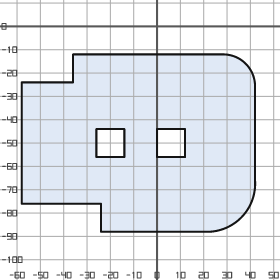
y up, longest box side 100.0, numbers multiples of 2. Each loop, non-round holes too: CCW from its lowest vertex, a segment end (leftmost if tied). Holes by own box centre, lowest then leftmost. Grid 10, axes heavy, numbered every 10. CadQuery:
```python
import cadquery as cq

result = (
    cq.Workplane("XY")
    .moveTo(-24.0, -88.0)
    .lineTo(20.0, -88.0)
    .threePointArc((36.0, -82.0), (42.0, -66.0))
    .lineTo(42.0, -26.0)
    .threePointArc((38.0, -16.0), (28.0, -12.0))
    .lineTo(-36.0, -12.0)
    .lineTo(-36.0, -24.0)
    .lineTo(-58.0, -24.0)
    .lineTo(-58.0, -76.0)
    .lineTo(-24.0, -76.0)
    .close()
    .moveTo(-26.0, -56.0)
    .lineTo(-14.0, -56.0)
    .lineTo(-14.0, -44.0)
    .lineTo(-26.0, -44.0)
    .close()
    .moveTo(0.0, -56.0)
    .lineTo(12.0, -56.0)
    .lineTo(12.0, -44.0)
    .lineTo(0.0, -44.0)
    .close()
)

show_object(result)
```